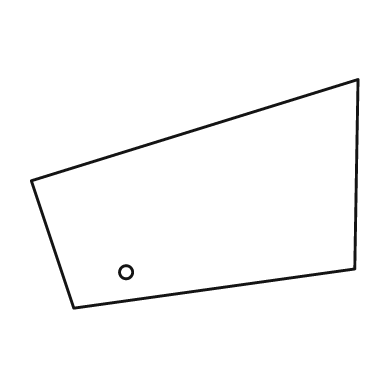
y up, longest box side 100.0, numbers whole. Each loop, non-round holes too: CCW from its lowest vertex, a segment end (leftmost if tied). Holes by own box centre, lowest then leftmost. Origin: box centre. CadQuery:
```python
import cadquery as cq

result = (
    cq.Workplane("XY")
    .moveTo(-37.0, -35.0)
    .lineTo(49.0, -23.0)
    .lineTo(50.0, 35.0)
    .lineTo(-50.0, 4.0)
    .close()
    .moveTo(-21.0, -24.0)
    .circle(2.0)
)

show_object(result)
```